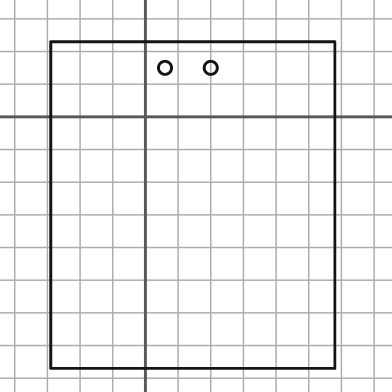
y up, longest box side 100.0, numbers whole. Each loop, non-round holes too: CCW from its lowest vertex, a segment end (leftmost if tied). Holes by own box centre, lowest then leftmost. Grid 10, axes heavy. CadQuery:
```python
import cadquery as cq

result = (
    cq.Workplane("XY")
    .moveTo(-29.0, -77.0)
    .lineTo(58.0, -77.0)
    .lineTo(58.0, 23.0)
    .lineTo(-29.0, 23.0)
    .close()
    .moveTo(6.0, 15.0)
    .circle(2.0)
    .moveTo(20.0, 15.0)
    .circle(2.0)
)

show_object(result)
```